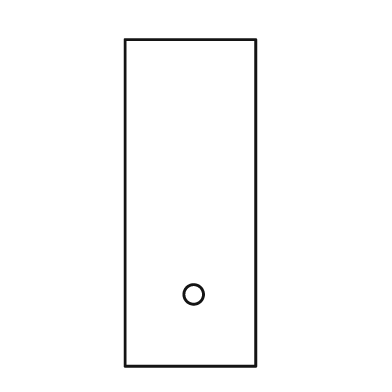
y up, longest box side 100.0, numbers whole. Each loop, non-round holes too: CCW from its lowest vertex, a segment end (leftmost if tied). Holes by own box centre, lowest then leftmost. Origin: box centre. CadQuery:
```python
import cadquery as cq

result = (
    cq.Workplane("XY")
    .moveTo(-20.0, -50.0)
    .lineTo(20.0, -50.0)
    .lineTo(20.0, 50.0)
    .lineTo(-20.0, 50.0)
    .close()
    .moveTo(1.0, -28.0)
    .circle(3.0)
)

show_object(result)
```